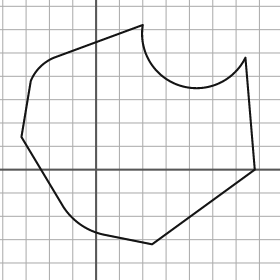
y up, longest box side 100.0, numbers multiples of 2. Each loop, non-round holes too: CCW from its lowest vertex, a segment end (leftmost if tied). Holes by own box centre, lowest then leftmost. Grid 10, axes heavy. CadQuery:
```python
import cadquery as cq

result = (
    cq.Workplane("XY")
    .moveTo(24.0, -32.0)
    .lineTo(68.0, 0.0)
    .lineTo(64.0, 48.0)
    .threePointArc((36.0, 36.0), (20.0, 62.0))
    .lineTo(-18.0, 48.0)
    .threePointArc((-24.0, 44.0), (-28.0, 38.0))
    .lineTo(-32.0, 14.0)
    .lineTo(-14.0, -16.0)
    .threePointArc((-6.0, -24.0), (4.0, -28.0))
    .close()
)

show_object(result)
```